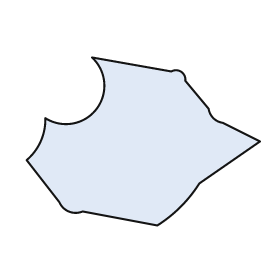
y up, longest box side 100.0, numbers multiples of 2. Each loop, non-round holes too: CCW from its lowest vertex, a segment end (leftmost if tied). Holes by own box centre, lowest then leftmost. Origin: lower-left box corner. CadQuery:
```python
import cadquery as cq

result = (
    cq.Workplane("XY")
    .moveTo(56.0, 0.0)
    .threePointArc((66.0, 8.0), (74.0, 18.0))
    .lineTo(100.0, 36.0)
    .lineTo(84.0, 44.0)
    .threePointArc((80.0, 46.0), (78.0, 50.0))
    .lineTo(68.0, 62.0)
    .threePointArc((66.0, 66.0), (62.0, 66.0))
    .lineTo(28.0, 72.0)
    .threePointArc((30.0, 50.0), (8.0, 46.0))
    .threePointArc((6.0, 36.0), (0.0, 28.0))
    .lineTo(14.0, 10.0)
    .threePointArc((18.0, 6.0), (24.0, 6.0))
    .close()
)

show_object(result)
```